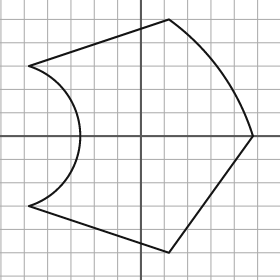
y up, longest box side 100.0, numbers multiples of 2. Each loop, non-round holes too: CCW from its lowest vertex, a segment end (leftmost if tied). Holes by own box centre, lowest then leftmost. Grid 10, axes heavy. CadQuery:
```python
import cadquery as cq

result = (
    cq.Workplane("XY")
    .moveTo(12.0, -50.0)
    .lineTo(48.0, 0.0)
    .threePointArc((34.0, 28.0), (12.0, 50.0))
    .lineTo(-48.0, 30.0)
    .threePointArc((-26.0, 0.0), (-48.0, -30.0))
    .close()
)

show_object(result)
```